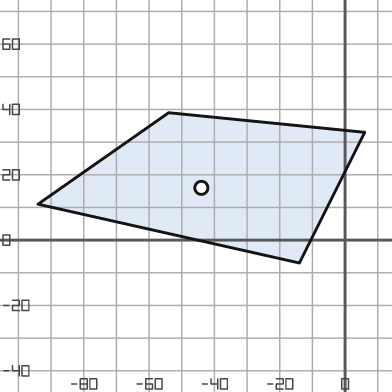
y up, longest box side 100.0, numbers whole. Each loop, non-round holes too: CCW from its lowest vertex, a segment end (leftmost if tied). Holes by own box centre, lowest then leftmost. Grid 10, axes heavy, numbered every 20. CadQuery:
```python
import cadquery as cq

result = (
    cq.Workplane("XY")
    .moveTo(-14.0, -7.0)
    .lineTo(6.0, 33.0)
    .lineTo(-54.0, 39.0)
    .lineTo(-94.0, 11.0)
    .close()
    .moveTo(-44.0, 16.0)
    .circle(2.0)
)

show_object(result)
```